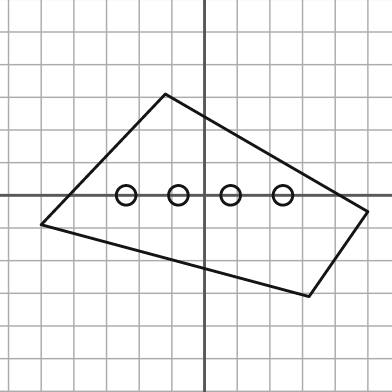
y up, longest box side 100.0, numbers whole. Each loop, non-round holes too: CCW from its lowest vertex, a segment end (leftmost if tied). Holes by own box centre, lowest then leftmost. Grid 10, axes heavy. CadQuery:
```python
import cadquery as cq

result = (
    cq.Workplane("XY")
    .moveTo(32.0, -31.0)
    .lineTo(50.0, -5.0)
    .lineTo(-12.0, 31.0)
    .lineTo(-50.0, -9.0)
    .close()
    .moveTo(-24.0, 0.0)
    .circle(3.0)
    .moveTo(-8.0, 0.0)
    .circle(3.0)
    .moveTo(8.0, 0.0)
    .circle(3.0)
    .moveTo(24.0, 0.0)
    .circle(3.0)
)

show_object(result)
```